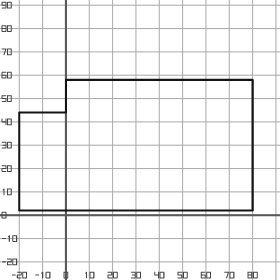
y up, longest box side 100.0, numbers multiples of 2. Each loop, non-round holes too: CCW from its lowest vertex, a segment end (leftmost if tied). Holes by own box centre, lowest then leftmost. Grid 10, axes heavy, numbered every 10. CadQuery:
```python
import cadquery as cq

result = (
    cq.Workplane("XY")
    .moveTo(-20.0, 2.0)
    .lineTo(80.0, 2.0)
    .lineTo(80.0, 58.0)
    .lineTo(0.0, 58.0)
    .lineTo(0.0, 44.0)
    .lineTo(-20.0, 44.0)
    .close()
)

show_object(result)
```